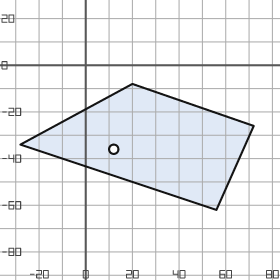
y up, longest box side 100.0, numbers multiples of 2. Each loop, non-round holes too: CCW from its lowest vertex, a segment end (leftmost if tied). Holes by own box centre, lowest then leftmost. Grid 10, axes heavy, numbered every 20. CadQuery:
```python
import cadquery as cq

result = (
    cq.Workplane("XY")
    .moveTo(56.0, -62.0)
    .lineTo(72.0, -26.0)
    .lineTo(20.0, -8.0)
    .lineTo(-28.0, -34.0)
    .close()
    .moveTo(12.0, -36.0)
    .circle(2.0)
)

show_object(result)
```